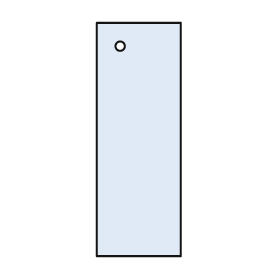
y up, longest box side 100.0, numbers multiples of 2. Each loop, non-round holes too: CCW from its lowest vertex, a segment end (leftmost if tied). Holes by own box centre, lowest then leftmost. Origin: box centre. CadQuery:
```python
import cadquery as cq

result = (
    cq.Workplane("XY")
    .moveTo(-18.0, -50.0)
    .lineTo(18.0, -50.0)
    .lineTo(18.0, 50.0)
    .lineTo(-18.0, 50.0)
    .close()
    .moveTo(-8.0, 40.0)
    .circle(2.0)
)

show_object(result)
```